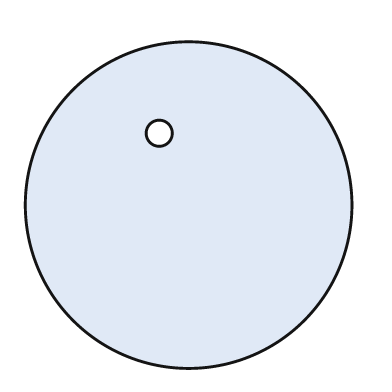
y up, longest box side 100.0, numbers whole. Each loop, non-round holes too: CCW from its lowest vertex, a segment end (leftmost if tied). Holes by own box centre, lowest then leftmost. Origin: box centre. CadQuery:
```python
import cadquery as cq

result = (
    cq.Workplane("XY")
    .moveTo(0.0, 0.0)
    .circle(50.0)
    .moveTo(-9.0, 22.0)
    .circle(4.0)
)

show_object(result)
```